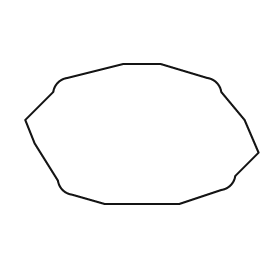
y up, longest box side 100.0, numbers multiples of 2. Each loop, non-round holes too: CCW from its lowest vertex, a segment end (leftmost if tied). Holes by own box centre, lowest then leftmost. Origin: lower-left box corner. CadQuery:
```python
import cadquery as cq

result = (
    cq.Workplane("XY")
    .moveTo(34.0, 0.0)
    .lineTo(66.0, 0.0)
    .lineTo(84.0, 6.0)
    .threePointArc((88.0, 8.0), (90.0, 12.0))
    .lineTo(100.0, 22.0)
    .lineTo(94.0, 36.0)
    .lineTo(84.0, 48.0)
    .threePointArc((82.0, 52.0), (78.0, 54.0))
    .lineTo(58.0, 60.0)
    .lineTo(42.0, 60.0)
    .lineTo(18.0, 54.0)
    .threePointArc((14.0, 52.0), (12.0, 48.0))
    .lineTo(0.0, 36.0)
    .lineTo(4.0, 26.0)
    .lineTo(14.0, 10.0)
    .threePointArc((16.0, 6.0), (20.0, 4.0))
    .close()
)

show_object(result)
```